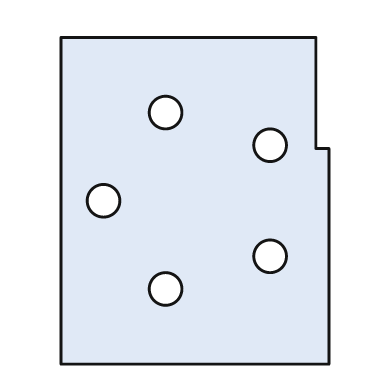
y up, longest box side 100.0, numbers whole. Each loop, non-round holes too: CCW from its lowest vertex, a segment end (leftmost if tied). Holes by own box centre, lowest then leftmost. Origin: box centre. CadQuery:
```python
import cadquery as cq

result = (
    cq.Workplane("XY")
    .moveTo(-41.0, -50.0)
    .lineTo(41.0, -50.0)
    .lineTo(41.0, 16.0)
    .lineTo(37.0, 16.0)
    .lineTo(37.0, 50.0)
    .lineTo(-41.0, 50.0)
    .close()
    .moveTo(-9.0, -27.0)
    .circle(5.0)
    .moveTo(23.0, -17.0)
    .circle(5.0)
    .moveTo(-28.0, 0.0)
    .circle(5.0)
    .moveTo(23.0, 17.0)
    .circle(5.0)
    .moveTo(-9.0, 27.0)
    .circle(5.0)
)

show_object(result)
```